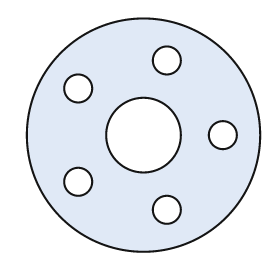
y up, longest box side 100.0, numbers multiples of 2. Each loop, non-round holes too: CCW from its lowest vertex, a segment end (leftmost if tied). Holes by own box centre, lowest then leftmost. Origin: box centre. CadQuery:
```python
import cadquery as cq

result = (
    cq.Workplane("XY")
    .moveTo(0.0, 0.0)
    .circle(50.0)
    .moveTo(10.0, -32.0)
    .circle(6.0)
    .moveTo(-28.0, -20.0)
    .circle(6.0)
    .moveTo(0.0, 0.0)
    .circle(16.0)
    .moveTo(34.0, 0.0)
    .circle(6.0)
    .moveTo(-28.0, 20.0)
    .circle(6.0)
    .moveTo(10.0, 32.0)
    .circle(6.0)
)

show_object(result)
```